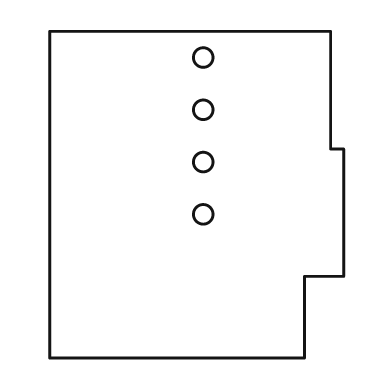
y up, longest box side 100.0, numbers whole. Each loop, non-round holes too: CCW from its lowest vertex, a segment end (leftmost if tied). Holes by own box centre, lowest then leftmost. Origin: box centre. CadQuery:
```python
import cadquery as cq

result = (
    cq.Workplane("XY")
    .moveTo(-45.0, -50.0)
    .lineTo(33.0, -50.0)
    .lineTo(33.0, -25.0)
    .lineTo(45.0, -25.0)
    .lineTo(45.0, 14.0)
    .lineTo(41.0, 14.0)
    .lineTo(41.0, 50.0)
    .lineTo(-45.0, 50.0)
    .close()
    .moveTo(2.0, -6.0)
    .circle(3.0)
    .moveTo(2.0, 10.0)
    .circle(3.0)
    .moveTo(2.0, 26.0)
    .circle(3.0)
    .moveTo(2.0, 42.0)
    .circle(3.0)
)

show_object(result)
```